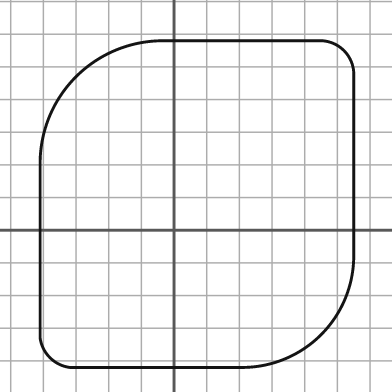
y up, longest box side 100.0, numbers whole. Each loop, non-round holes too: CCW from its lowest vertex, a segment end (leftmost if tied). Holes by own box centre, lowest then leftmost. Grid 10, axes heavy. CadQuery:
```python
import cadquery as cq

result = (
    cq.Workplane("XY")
    .moveTo(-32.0, -42.0)
    .lineTo(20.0, -42.0)
    .threePointArc((45.0, -32.0), (55.0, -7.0))
    .lineTo(55.0, 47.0)
    .threePointArc((52.0, 55.0), (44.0, 58.0))
    .lineTo(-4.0, 58.0)
    .threePointArc((-30.0, 47.0), (-41.0, 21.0))
    .lineTo(-41.0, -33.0)
    .threePointArc((-38.0, -39.0), (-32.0, -42.0))
    .close()
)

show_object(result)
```